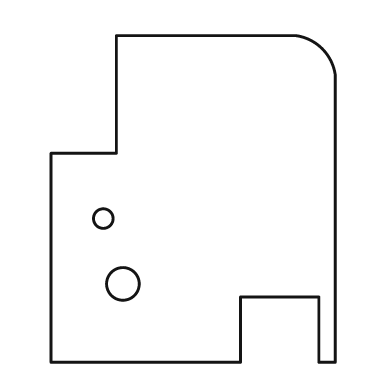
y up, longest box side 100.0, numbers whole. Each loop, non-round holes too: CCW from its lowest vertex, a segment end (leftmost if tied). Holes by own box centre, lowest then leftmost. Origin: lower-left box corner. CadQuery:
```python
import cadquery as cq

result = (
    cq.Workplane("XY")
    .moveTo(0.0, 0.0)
    .lineTo(58.0, 0.0)
    .lineTo(58.0, 20.0)
    .lineTo(82.0, 20.0)
    .lineTo(82.0, 0.0)
    .lineTo(87.0, 0.0)
    .lineTo(87.0, 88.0)
    .threePointArc((83.0, 96.0), (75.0, 100.0))
    .lineTo(20.0, 100.0)
    .lineTo(20.0, 64.0)
    .lineTo(0.0, 64.0)
    .close()
    .moveTo(22.0, 24.0)
    .circle(5.0)
    .moveTo(16.0, 44.0)
    .circle(3.0)
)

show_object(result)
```